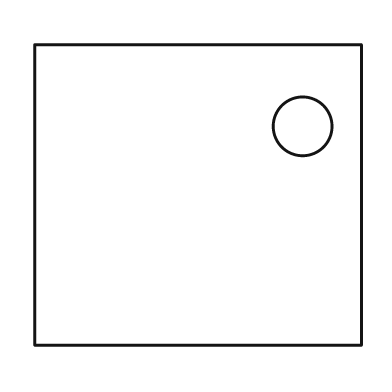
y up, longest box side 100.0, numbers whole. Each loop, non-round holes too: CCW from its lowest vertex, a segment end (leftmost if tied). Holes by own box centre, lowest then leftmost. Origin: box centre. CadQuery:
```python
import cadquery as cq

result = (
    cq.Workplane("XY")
    .moveTo(-50.0, -46.0)
    .lineTo(50.0, -46.0)
    .lineTo(50.0, 46.0)
    .lineTo(-50.0, 46.0)
    .close()
    .moveTo(32.0, 21.0)
    .circle(9.0)
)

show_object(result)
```